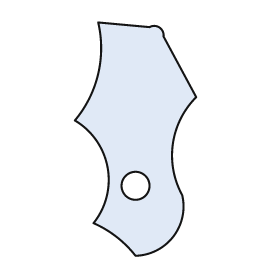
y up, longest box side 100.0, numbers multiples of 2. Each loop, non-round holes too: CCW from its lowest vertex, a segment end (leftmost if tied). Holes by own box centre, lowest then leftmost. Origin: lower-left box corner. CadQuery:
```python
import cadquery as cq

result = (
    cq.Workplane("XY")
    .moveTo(26.0, 0.0)
    .threePointArc((42.0, 8.0), (46.0, 26.0))
    .threePointArc((42.0, 48.0), (52.0, 68.0))
    .lineTo(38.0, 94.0)
    .threePointArc((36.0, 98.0), (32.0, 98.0))
    .lineTo(10.0, 100.0)
    .threePointArc((10.0, 78.0), (0.0, 58.0))
    .threePointArc((14.0, 38.0), (8.0, 14.0))
    .threePointArc((18.0, 8.0), (26.0, 0.0))
    .close()
    .moveTo(26.0, 30.0)
    .circle(6.0)
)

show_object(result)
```